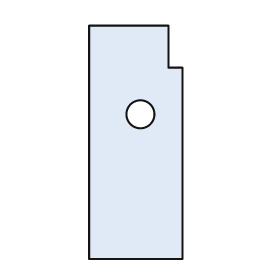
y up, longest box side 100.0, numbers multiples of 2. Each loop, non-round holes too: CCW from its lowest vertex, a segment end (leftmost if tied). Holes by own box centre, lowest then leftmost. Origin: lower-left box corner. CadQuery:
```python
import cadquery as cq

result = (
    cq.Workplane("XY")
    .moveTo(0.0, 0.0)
    .lineTo(40.0, 0.0)
    .lineTo(40.0, 82.0)
    .lineTo(34.0, 82.0)
    .lineTo(34.0, 100.0)
    .lineTo(0.0, 100.0)
    .close()
    .moveTo(22.0, 62.0)
    .circle(6.0)
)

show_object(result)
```